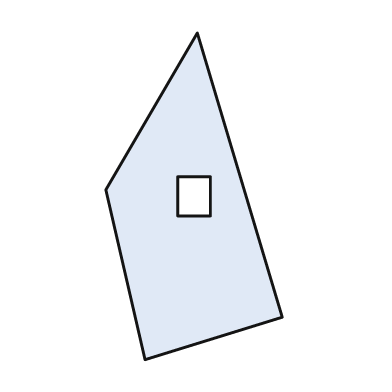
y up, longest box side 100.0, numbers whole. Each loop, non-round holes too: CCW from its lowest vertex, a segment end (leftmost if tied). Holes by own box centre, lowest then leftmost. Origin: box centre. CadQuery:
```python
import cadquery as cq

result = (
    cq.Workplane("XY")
    .moveTo(-15.0, -50.0)
    .lineTo(27.0, -37.0)
    .lineTo(1.0, 50.0)
    .lineTo(-27.0, 2.0)
    .close()
    .moveTo(-5.0, -6.0)
    .lineTo(5.0, -6.0)
    .lineTo(5.0, 6.0)
    .lineTo(-5.0, 6.0)
    .close()
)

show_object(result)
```